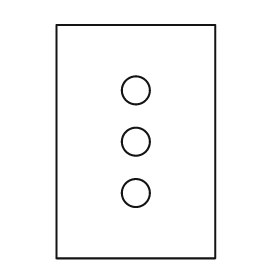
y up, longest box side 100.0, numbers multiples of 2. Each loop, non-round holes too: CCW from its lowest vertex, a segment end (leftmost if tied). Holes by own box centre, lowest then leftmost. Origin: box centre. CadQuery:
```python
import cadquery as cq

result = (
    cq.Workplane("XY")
    .moveTo(-34.0, -50.0)
    .lineTo(34.0, -50.0)
    .lineTo(34.0, 50.0)
    .lineTo(-34.0, 50.0)
    .close()
    .moveTo(0.0, -22.0)
    .circle(6.0)
    .moveTo(0.0, 0.0)
    .circle(6.0)
    .moveTo(0.0, 22.0)
    .circle(6.0)
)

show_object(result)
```